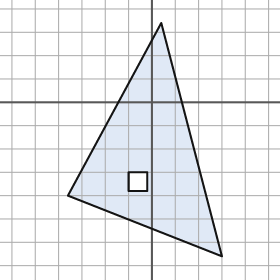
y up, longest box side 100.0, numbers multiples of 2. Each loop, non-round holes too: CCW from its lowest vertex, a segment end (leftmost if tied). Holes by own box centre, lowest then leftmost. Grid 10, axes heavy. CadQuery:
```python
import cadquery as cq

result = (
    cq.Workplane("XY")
    .moveTo(30.0, -66.0)
    .lineTo(4.0, 34.0)
    .lineTo(-36.0, -40.0)
    .close()
    .moveTo(-10.0, -38.0)
    .lineTo(-2.0, -38.0)
    .lineTo(-2.0, -30.0)
    .lineTo(-10.0, -30.0)
    .close()
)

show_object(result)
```